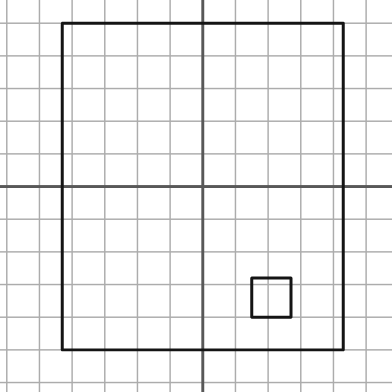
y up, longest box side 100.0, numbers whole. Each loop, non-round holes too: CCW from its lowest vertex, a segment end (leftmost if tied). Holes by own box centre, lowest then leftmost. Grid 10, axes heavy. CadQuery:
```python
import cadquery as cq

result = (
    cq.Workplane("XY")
    .moveTo(-43.0, -50.0)
    .lineTo(43.0, -50.0)
    .lineTo(43.0, 50.0)
    .lineTo(-43.0, 50.0)
    .close()
    .moveTo(15.0, -40.0)
    .lineTo(27.0, -40.0)
    .lineTo(27.0, -28.0)
    .lineTo(15.0, -28.0)
    .close()
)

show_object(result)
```